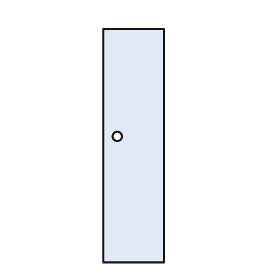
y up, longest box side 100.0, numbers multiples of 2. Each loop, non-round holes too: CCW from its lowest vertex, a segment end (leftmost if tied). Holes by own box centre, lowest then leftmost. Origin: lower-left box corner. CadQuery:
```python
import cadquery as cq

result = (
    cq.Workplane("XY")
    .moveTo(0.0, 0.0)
    .lineTo(26.0, 0.0)
    .lineTo(26.0, 100.0)
    .lineTo(0.0, 100.0)
    .close()
    .moveTo(6.0, 54.0)
    .circle(2.0)
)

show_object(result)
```